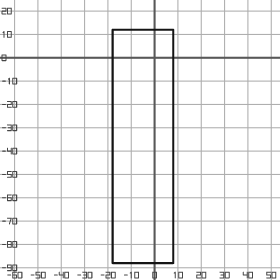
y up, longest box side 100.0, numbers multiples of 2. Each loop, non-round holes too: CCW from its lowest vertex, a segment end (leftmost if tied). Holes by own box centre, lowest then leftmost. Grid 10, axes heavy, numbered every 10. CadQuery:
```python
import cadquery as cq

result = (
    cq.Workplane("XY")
    .moveTo(-18.0, -88.0)
    .lineTo(8.0, -88.0)
    .lineTo(8.0, 12.0)
    .lineTo(-18.0, 12.0)
    .close()
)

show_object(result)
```